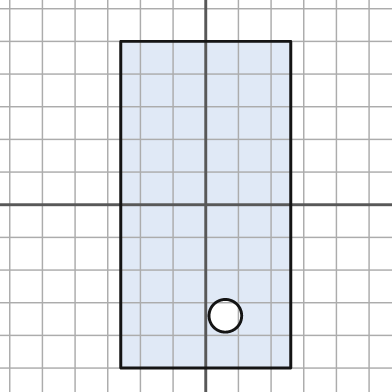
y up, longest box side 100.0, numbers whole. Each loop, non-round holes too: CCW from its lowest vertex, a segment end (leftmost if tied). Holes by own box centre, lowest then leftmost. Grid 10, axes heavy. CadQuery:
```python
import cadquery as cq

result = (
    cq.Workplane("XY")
    .moveTo(-26.0, -50.0)
    .lineTo(26.0, -50.0)
    .lineTo(26.0, 50.0)
    .lineTo(-26.0, 50.0)
    .close()
    .moveTo(6.0, -34.0)
    .circle(5.0)
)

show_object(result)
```